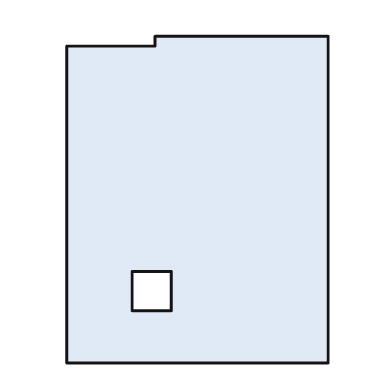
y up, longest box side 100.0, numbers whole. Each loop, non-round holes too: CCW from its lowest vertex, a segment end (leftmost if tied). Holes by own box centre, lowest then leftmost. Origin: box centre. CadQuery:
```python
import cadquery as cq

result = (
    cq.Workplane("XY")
    .moveTo(-40.0, -50.0)
    .lineTo(40.0, -50.0)
    .lineTo(40.0, 50.0)
    .lineTo(-13.0, 50.0)
    .lineTo(-13.0, 47.0)
    .lineTo(-40.0, 47.0)
    .close()
    .moveTo(-20.0, -34.0)
    .lineTo(-8.0, -34.0)
    .lineTo(-8.0, -22.0)
    .lineTo(-20.0, -22.0)
    .close()
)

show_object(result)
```